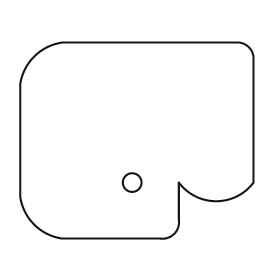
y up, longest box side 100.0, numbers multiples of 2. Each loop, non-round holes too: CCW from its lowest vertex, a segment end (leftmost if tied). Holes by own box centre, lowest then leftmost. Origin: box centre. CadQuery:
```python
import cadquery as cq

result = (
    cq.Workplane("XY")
    .moveTo(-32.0, -42.0)
    .lineTo(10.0, -42.0)
    .threePointArc((16.0, -40.0), (18.0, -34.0))
    .lineTo(18.0, -18.0)
    .threePointArc((34.0, -26.0), (50.0, -18.0))
    .lineTo(50.0, 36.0)
    .threePointArc((48.0, 40.0), (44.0, 42.0))
    .lineTo(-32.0, 42.0)
    .threePointArc((-44.0, 36.0), (-50.0, 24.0))
    .lineTo(-50.0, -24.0)
    .threePointArc((-44.0, -36.0), (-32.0, -42.0))
    .close()
    .moveTo(-2.0, -18.0)
    .circle(4.0)
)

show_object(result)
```